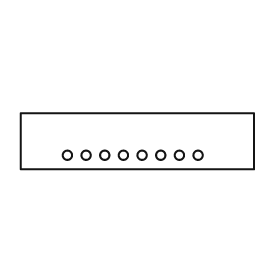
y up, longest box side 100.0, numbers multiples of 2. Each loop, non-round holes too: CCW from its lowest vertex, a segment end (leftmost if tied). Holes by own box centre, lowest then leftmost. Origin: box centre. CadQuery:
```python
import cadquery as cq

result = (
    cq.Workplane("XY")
    .moveTo(-50.0, -12.0)
    .lineTo(50.0, -12.0)
    .lineTo(50.0, 12.0)
    .lineTo(-50.0, 12.0)
    .close()
    .moveTo(-30.0, -6.0)
    .circle(2.0)
    .moveTo(-22.0, -6.0)
    .circle(2.0)
    .moveTo(-14.0, -6.0)
    .circle(2.0)
    .moveTo(-6.0, -6.0)
    .circle(2.0)
    .moveTo(2.0, -6.0)
    .circle(2.0)
    .moveTo(10.0, -6.0)
    .circle(2.0)
    .moveTo(18.0, -6.0)
    .circle(2.0)
    .moveTo(26.0, -6.0)
    .circle(2.0)
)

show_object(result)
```